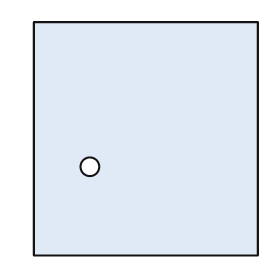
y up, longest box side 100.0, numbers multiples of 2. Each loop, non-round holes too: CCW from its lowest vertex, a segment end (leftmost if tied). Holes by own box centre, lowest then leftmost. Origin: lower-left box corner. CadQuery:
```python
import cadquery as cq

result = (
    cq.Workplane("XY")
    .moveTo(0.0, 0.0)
    .lineTo(96.0, 0.0)
    .lineTo(96.0, 100.0)
    .lineTo(0.0, 100.0)
    .close()
    .moveTo(24.0, 38.0)
    .circle(4.0)
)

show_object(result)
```